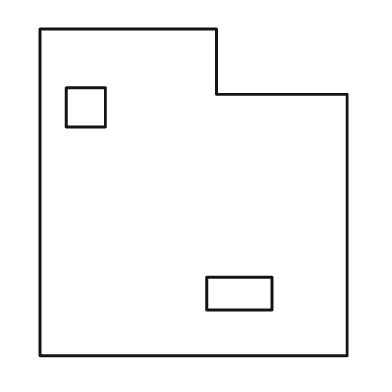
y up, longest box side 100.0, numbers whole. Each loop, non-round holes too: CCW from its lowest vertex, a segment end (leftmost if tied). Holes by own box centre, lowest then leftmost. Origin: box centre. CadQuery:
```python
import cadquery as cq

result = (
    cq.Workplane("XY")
    .moveTo(-47.0, -50.0)
    .lineTo(47.0, -50.0)
    .lineTo(47.0, 30.0)
    .lineTo(7.0, 30.0)
    .lineTo(7.0, 50.0)
    .lineTo(-47.0, 50.0)
    .close()
    .moveTo(4.0, -36.0)
    .lineTo(24.0, -36.0)
    .lineTo(24.0, -26.0)
    .lineTo(4.0, -26.0)
    .close()
    .moveTo(-39.0, 20.0)
    .lineTo(-27.0, 20.0)
    .lineTo(-27.0, 32.0)
    .lineTo(-39.0, 32.0)
    .close()
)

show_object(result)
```